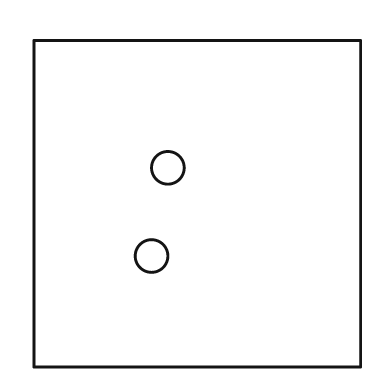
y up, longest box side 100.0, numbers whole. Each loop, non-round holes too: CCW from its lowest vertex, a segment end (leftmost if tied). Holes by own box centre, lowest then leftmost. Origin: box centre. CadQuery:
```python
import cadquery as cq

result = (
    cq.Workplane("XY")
    .moveTo(-50.0, -50.0)
    .lineTo(50.0, -50.0)
    .lineTo(50.0, 50.0)
    .lineTo(-50.0, 50.0)
    .close()
    .moveTo(-14.0, -16.0)
    .circle(5.0)
    .moveTo(-9.0, 11.0)
    .circle(5.0)
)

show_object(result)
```